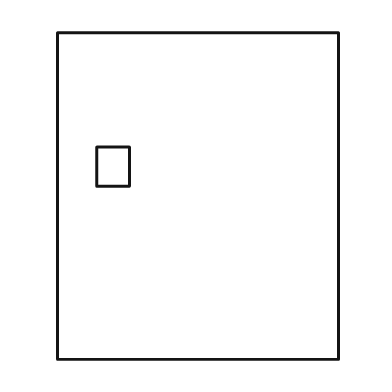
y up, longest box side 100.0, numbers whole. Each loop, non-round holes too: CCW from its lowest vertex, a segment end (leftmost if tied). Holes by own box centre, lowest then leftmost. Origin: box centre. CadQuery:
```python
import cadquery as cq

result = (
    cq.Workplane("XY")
    .moveTo(-43.0, -50.0)
    .lineTo(43.0, -50.0)
    .lineTo(43.0, 50.0)
    .lineTo(-43.0, 50.0)
    .close()
    .moveTo(-31.0, 3.0)
    .lineTo(-21.0, 3.0)
    .lineTo(-21.0, 15.0)
    .lineTo(-31.0, 15.0)
    .close()
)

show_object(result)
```